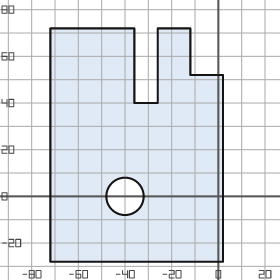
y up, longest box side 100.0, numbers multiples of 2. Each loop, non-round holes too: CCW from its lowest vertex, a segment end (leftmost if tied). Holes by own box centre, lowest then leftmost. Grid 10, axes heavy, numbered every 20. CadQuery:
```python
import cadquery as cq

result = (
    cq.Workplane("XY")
    .moveTo(-72.0, -28.0)
    .lineTo(2.0, -28.0)
    .lineTo(2.0, 52.0)
    .lineTo(-12.0, 52.0)
    .lineTo(-12.0, 72.0)
    .lineTo(-26.0, 72.0)
    .lineTo(-26.0, 40.0)
    .lineTo(-36.0, 40.0)
    .lineTo(-36.0, 72.0)
    .lineTo(-72.0, 72.0)
    .close()
    .moveTo(-40.0, 0.0)
    .circle(8.0)
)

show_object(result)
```